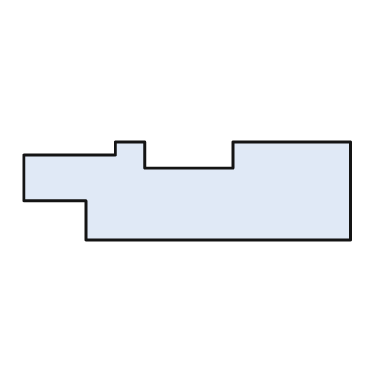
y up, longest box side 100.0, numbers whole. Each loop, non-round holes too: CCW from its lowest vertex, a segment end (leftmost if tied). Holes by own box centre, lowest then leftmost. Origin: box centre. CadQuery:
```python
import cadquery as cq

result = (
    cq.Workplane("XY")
    .moveTo(-31.0, -15.0)
    .lineTo(50.0, -15.0)
    .lineTo(50.0, 15.0)
    .lineTo(14.0, 15.0)
    .lineTo(14.0, 7.0)
    .lineTo(-13.0, 7.0)
    .lineTo(-13.0, 15.0)
    .lineTo(-22.0, 15.0)
    .lineTo(-22.0, 11.0)
    .lineTo(-50.0, 11.0)
    .lineTo(-50.0, -3.0)
    .lineTo(-31.0, -3.0)
    .close()
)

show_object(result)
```